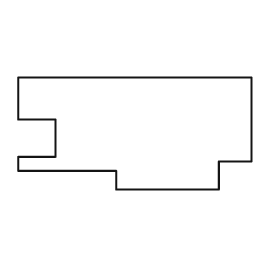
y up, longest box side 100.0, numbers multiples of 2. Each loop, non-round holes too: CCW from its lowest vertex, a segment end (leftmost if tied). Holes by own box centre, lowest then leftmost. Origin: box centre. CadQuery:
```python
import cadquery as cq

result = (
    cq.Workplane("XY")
    .moveTo(-8.0, -24.0)
    .lineTo(36.0, -24.0)
    .lineTo(36.0, -12.0)
    .lineTo(50.0, -12.0)
    .lineTo(50.0, 24.0)
    .lineTo(-50.0, 24.0)
    .lineTo(-50.0, 6.0)
    .lineTo(-34.0, 6.0)
    .lineTo(-34.0, -10.0)
    .lineTo(-50.0, -10.0)
    .lineTo(-50.0, -16.0)
    .lineTo(-8.0, -16.0)
    .close()
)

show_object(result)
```